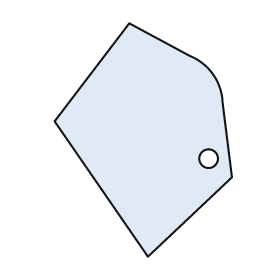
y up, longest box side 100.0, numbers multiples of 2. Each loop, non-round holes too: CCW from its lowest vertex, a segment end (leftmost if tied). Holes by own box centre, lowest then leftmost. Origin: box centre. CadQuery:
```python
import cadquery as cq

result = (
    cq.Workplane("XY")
    .moveTo(2.0, -50.0)
    .lineTo(38.0, -16.0)
    .lineTo(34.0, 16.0)
    .threePointArc((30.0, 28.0), (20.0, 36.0))
    .lineTo(-6.0, 50.0)
    .lineTo(-38.0, 8.0)
    .close()
    .moveTo(28.0, -8.0)
    .circle(4.0)
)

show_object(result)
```